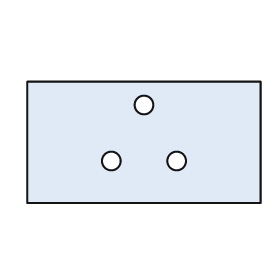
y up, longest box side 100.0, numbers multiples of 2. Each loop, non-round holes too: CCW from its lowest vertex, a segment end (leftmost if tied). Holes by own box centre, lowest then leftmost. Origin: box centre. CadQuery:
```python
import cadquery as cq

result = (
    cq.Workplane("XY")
    .moveTo(-50.0, -26.0)
    .lineTo(50.0, -26.0)
    .lineTo(50.0, 26.0)
    .lineTo(-50.0, 26.0)
    .close()
    .moveTo(-14.0, -8.0)
    .circle(4.0)
    .moveTo(14.0, -8.0)
    .circle(4.0)
    .moveTo(0.0, 16.0)
    .circle(4.0)
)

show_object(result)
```